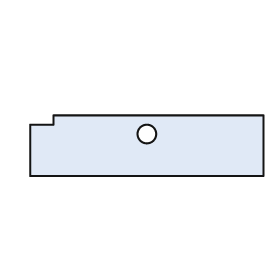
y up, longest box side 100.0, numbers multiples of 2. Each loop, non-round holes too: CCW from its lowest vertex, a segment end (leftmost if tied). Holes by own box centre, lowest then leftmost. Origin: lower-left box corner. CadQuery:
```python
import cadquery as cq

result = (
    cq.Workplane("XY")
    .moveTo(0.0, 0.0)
    .lineTo(100.0, 0.0)
    .lineTo(100.0, 26.0)
    .lineTo(10.0, 26.0)
    .lineTo(10.0, 22.0)
    .lineTo(0.0, 22.0)
    .close()
    .moveTo(50.0, 18.0)
    .circle(4.0)
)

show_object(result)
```